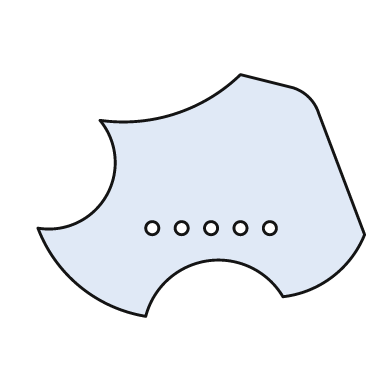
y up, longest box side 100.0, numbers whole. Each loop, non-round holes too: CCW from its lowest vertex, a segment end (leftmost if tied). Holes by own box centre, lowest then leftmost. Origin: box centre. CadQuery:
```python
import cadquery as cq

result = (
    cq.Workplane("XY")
    .moveTo(-17.0, -37.0)
    .threePointArc((2.0, -20.0), (25.0, -31.0))
    .threePointArc((40.0, -25.0), (50.0, -12.0))
    .lineTo(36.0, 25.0)
    .threePointArc((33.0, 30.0), (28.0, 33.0))
    .lineTo(12.0, 37.0)
    .threePointArc((-8.0, 25.0), (-31.0, 23.0))
    .threePointArc((-29.0, 0.0), (-50.0, -10.0))
    .threePointArc((-37.0, -28.0), (-17.0, -37.0))
    .close()
    .moveTo(-15.0, -10.0)
    .circle(2.0)
    .moveTo(-6.0, -10.0)
    .circle(2.0)
    .moveTo(3.0, -10.0)
    .circle(2.0)
    .moveTo(12.0, -10.0)
    .circle(2.0)
    .moveTo(21.0, -10.0)
    .circle(2.0)
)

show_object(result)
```